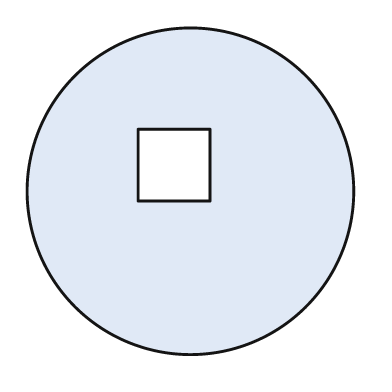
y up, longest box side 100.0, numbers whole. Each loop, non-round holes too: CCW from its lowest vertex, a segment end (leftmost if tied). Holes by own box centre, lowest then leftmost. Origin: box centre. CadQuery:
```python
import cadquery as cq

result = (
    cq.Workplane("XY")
    .moveTo(0.0, 0.0)
    .circle(50.0)
    .moveTo(-16.0, -3.0)
    .lineTo(6.0, -3.0)
    .lineTo(6.0, 19.0)
    .lineTo(-16.0, 19.0)
    .close()
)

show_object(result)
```